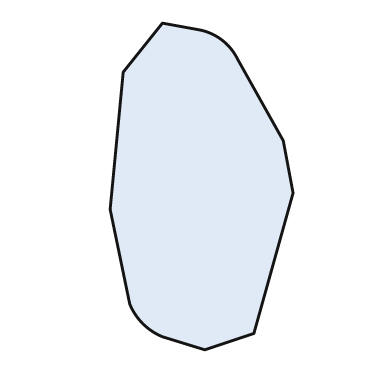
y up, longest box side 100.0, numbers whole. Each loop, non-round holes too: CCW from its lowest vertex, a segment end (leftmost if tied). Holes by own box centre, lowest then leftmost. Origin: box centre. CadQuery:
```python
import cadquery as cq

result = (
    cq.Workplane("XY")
    .moveTo(1.0, -50.0)
    .lineTo(16.0, -45.0)
    .lineTo(28.0, -2.0)
    .lineTo(25.0, 14.0)
    .lineTo(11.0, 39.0)
    .threePointArc((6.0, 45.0), (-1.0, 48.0))
    .lineTo(-12.0, 50.0)
    .lineTo(-24.0, 35.0)
    .lineTo(-28.0, -7.0)
    .lineTo(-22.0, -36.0)
    .threePointArc((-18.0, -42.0), (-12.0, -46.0))
    .close()
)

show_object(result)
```